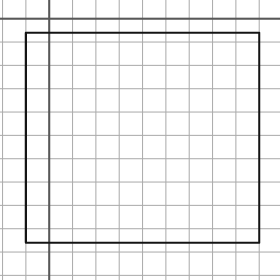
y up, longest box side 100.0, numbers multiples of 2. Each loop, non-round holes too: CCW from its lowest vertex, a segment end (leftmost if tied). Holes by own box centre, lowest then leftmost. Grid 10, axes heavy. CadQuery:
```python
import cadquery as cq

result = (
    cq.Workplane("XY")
    .moveTo(-10.0, -96.0)
    .lineTo(90.0, -96.0)
    .lineTo(90.0, -6.0)
    .lineTo(-10.0, -6.0)
    .close()
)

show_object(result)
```